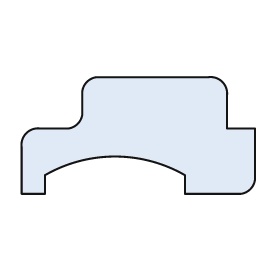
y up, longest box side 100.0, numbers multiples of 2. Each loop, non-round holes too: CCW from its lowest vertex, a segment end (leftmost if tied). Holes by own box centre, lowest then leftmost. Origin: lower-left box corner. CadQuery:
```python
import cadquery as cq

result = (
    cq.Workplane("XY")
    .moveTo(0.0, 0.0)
    .lineTo(10.0, 0.0)
    .lineTo(10.0, 8.0)
    .threePointArc((40.0, 16.0), (70.0, 8.0))
    .lineTo(70.0, 0.0)
    .lineTo(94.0, 0.0)
    .threePointArc((98.0, 2.0), (100.0, 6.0))
    .lineTo(100.0, 28.0)
    .lineTo(88.0, 28.0)
    .lineTo(88.0, 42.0)
    .threePointArc((86.0, 48.0), (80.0, 50.0))
    .lineTo(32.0, 50.0)
    .threePointArc((28.0, 48.0), (26.0, 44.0))
    .lineTo(26.0, 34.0)
    .threePointArc((24.0, 30.0), (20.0, 28.0))
    .lineTo(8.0, 28.0)
    .threePointArc((2.0, 26.0), (0.0, 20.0))
    .close()
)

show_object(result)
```